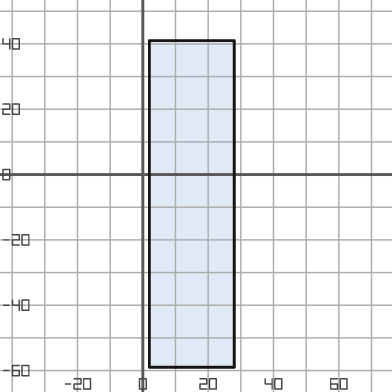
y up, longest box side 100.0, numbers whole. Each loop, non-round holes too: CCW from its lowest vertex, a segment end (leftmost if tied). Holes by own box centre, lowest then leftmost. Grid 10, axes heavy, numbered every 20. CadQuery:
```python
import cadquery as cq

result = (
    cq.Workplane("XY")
    .moveTo(2.0, -59.0)
    .lineTo(28.0, -59.0)
    .lineTo(28.0, 41.0)
    .lineTo(2.0, 41.0)
    .close()
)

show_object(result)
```